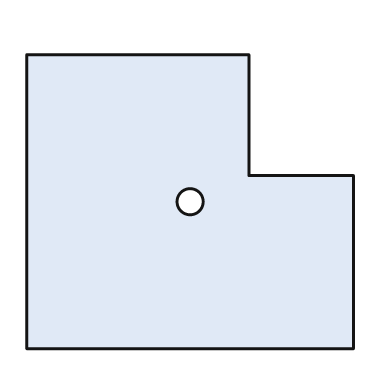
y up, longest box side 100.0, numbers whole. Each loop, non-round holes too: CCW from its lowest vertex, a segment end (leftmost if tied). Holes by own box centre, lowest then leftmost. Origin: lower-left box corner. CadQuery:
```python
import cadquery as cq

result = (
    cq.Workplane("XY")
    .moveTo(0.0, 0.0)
    .lineTo(100.0, 0.0)
    .lineTo(100.0, 53.0)
    .lineTo(68.0, 53.0)
    .lineTo(68.0, 90.0)
    .lineTo(0.0, 90.0)
    .close()
    .moveTo(50.0, 45.0)
    .circle(4.0)
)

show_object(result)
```